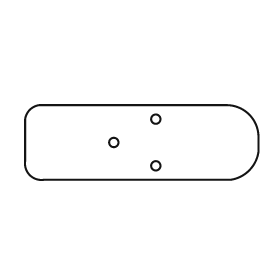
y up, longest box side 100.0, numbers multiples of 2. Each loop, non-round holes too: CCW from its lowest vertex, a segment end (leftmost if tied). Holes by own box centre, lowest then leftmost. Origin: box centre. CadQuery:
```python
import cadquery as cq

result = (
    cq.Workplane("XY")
    .moveTo(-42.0, -16.0)
    .lineTo(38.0, -16.0)
    .threePointArc((46.0, -12.0), (50.0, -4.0))
    .lineTo(50.0, 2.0)
    .threePointArc((46.0, 12.0), (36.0, 16.0))
    .lineTo(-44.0, 16.0)
    .threePointArc((-48.0, 14.0), (-50.0, 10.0))
    .lineTo(-50.0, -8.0)
    .threePointArc((-48.0, -14.0), (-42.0, -16.0))
    .close()
    .moveTo(6.0, -10.0)
    .circle(2.0)
    .moveTo(-12.0, 0.0)
    .circle(2.0)
    .moveTo(6.0, 10.0)
    .circle(2.0)
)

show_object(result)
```